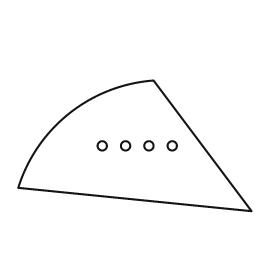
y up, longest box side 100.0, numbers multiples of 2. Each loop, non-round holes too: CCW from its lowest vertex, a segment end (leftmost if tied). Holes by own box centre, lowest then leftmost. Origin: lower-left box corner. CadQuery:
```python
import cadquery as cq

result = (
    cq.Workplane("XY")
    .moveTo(100.0, 0.0)
    .lineTo(58.0, 56.0)
    .threePointArc((22.0, 42.0), (0.0, 10.0))
    .close()
    .moveTo(36.0, 28.0)
    .circle(2.0)
    .moveTo(46.0, 28.0)
    .circle(2.0)
    .moveTo(56.0, 28.0)
    .circle(2.0)
    .moveTo(66.0, 28.0)
    .circle(2.0)
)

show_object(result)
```